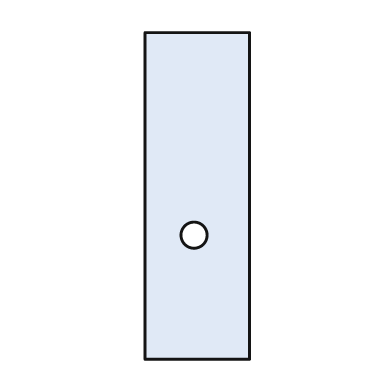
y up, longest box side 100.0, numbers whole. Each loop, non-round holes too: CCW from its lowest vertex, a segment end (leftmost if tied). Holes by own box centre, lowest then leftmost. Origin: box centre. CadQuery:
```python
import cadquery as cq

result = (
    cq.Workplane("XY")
    .moveTo(-16.0, -50.0)
    .lineTo(16.0, -50.0)
    .lineTo(16.0, 50.0)
    .lineTo(-16.0, 50.0)
    .close()
    .moveTo(-1.0, -12.0)
    .circle(4.0)
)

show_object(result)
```